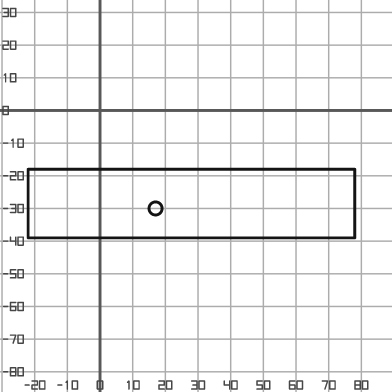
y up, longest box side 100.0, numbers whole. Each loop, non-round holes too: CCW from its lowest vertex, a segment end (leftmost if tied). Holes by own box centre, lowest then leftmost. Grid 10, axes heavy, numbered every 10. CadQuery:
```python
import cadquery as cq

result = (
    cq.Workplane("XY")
    .moveTo(-22.0, -39.0)
    .lineTo(78.0, -39.0)
    .lineTo(78.0, -18.0)
    .lineTo(-22.0, -18.0)
    .close()
    .moveTo(17.0, -30.0)
    .circle(2.0)
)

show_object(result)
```